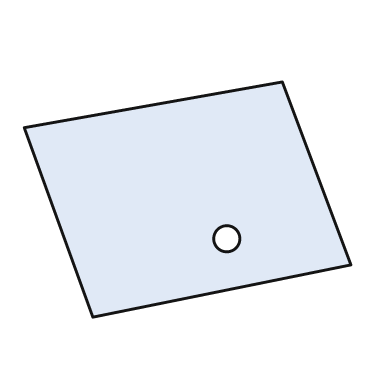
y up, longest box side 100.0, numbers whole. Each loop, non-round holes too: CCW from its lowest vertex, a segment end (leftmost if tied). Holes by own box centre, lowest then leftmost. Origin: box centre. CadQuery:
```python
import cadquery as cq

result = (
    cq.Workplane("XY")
    .moveTo(-29.0, -36.0)
    .lineTo(50.0, -20.0)
    .lineTo(29.0, 36.0)
    .lineTo(-50.0, 22.0)
    .close()
    .moveTo(12.0, -12.0)
    .circle(4.0)
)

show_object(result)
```